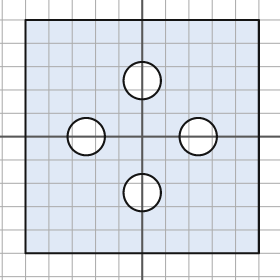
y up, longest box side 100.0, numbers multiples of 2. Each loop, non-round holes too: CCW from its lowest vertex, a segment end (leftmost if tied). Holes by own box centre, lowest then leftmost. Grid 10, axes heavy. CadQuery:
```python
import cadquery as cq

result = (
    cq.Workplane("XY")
    .moveTo(-50.0, -50.0)
    .lineTo(50.0, -50.0)
    .lineTo(50.0, 50.0)
    .lineTo(-50.0, 50.0)
    .close()
    .moveTo(0.0, -24.0)
    .circle(8.0)
    .moveTo(-24.0, 0.0)
    .circle(8.0)
    .moveTo(24.0, 0.0)
    .circle(8.0)
    .moveTo(0.0, 24.0)
    .circle(8.0)
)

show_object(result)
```